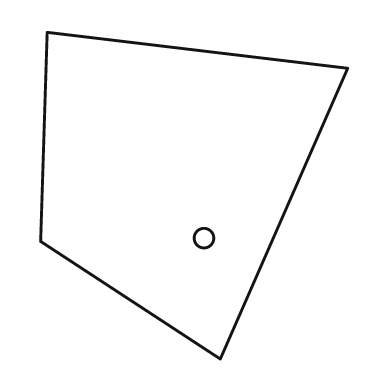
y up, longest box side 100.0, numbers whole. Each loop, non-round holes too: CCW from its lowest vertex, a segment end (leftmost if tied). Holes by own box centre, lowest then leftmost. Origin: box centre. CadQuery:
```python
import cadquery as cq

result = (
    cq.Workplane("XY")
    .moveTo(8.0, -50.0)
    .lineTo(47.0, 39.0)
    .lineTo(-45.0, 50.0)
    .lineTo(-47.0, -14.0)
    .close()
    .moveTo(3.0, -13.0)
    .circle(3.0)
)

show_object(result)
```